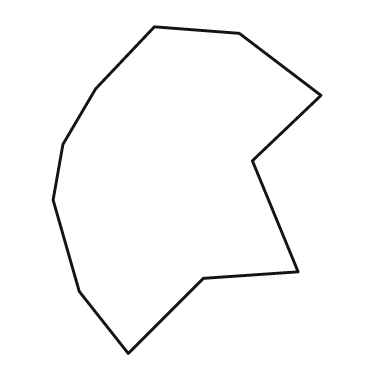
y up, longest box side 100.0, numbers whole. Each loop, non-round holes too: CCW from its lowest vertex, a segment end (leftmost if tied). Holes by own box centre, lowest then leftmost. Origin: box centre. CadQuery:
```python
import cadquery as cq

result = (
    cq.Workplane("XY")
    .moveTo(-18.0, -50.0)
    .lineTo(5.0, -27.0)
    .lineTo(34.0, -25.0)
    .lineTo(20.0, 9.0)
    .lineTo(41.0, 29.0)
    .lineTo(16.0, 48.0)
    .lineTo(-10.0, 50.0)
    .lineTo(-28.0, 31.0)
    .lineTo(-38.0, 14.0)
    .lineTo(-41.0, -3.0)
    .lineTo(-33.0, -31.0)
    .close()
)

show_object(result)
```